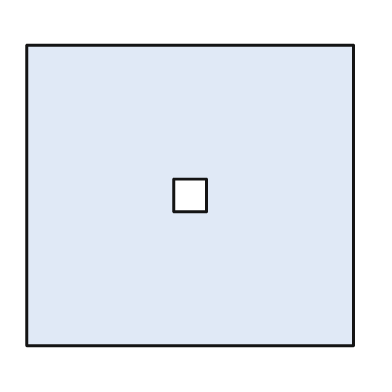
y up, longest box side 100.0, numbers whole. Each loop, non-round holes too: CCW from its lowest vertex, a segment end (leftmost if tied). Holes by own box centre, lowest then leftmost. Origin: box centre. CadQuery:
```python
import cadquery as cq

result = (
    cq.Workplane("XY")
    .moveTo(-50.0, -46.0)
    .lineTo(50.0, -46.0)
    .lineTo(50.0, 46.0)
    .lineTo(-50.0, 46.0)
    .close()
    .moveTo(-5.0, -5.0)
    .lineTo(5.0, -5.0)
    .lineTo(5.0, 5.0)
    .lineTo(-5.0, 5.0)
    .close()
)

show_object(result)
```